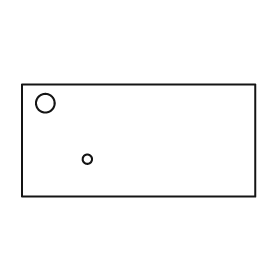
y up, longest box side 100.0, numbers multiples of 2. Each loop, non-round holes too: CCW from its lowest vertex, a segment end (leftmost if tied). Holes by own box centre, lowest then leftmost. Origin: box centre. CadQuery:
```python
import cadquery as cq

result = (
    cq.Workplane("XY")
    .moveTo(-50.0, -24.0)
    .lineTo(50.0, -24.0)
    .lineTo(50.0, 24.0)
    .lineTo(-50.0, 24.0)
    .close()
    .moveTo(-22.0, -8.0)
    .circle(2.0)
    .moveTo(-40.0, 16.0)
    .circle(4.0)
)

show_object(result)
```